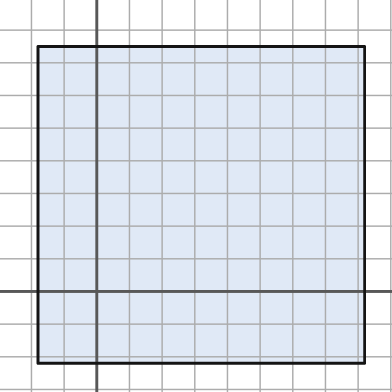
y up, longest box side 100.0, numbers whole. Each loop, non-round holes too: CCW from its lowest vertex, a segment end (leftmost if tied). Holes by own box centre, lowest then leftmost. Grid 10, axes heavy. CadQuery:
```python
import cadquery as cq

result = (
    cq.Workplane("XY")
    .moveTo(-18.0, -22.0)
    .lineTo(82.0, -22.0)
    .lineTo(82.0, 75.0)
    .lineTo(-18.0, 75.0)
    .close()
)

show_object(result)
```